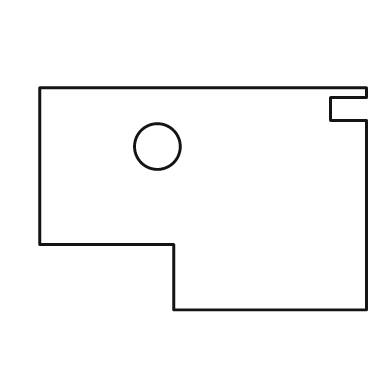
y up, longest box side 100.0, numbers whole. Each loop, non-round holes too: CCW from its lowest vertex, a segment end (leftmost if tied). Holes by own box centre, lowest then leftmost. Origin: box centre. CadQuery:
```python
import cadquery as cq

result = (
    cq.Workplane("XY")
    .moveTo(-9.0, -34.0)
    .lineTo(50.0, -34.0)
    .lineTo(50.0, 24.0)
    .lineTo(39.0, 24.0)
    .lineTo(39.0, 31.0)
    .lineTo(50.0, 31.0)
    .lineTo(50.0, 34.0)
    .lineTo(-50.0, 34.0)
    .lineTo(-50.0, -14.0)
    .lineTo(-9.0, -14.0)
    .close()
    .moveTo(-14.0, 16.0)
    .circle(7.0)
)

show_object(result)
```